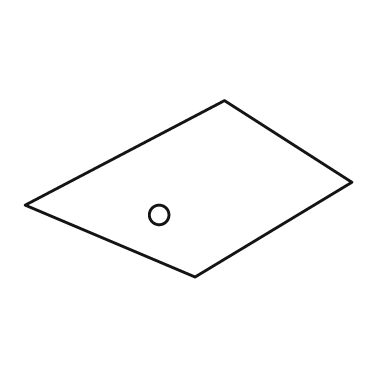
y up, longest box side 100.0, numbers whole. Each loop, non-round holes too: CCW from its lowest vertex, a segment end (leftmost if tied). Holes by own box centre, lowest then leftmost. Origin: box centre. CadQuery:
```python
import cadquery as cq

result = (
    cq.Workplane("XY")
    .moveTo(2.0, -27.0)
    .lineTo(50.0, 2.0)
    .lineTo(11.0, 27.0)
    .lineTo(-50.0, -5.0)
    .close()
    .moveTo(-9.0, -8.0)
    .circle(3.0)
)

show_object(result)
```